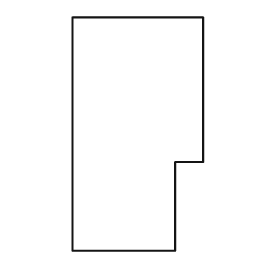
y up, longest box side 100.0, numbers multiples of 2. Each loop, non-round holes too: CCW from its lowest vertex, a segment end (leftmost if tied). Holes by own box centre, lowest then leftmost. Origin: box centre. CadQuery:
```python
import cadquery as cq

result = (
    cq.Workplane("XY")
    .moveTo(-28.0, -50.0)
    .lineTo(16.0, -50.0)
    .lineTo(16.0, -12.0)
    .lineTo(28.0, -12.0)
    .lineTo(28.0, 50.0)
    .lineTo(-28.0, 50.0)
    .close()
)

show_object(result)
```